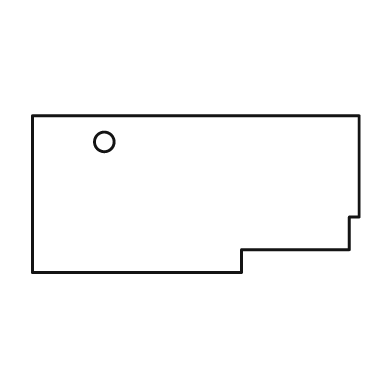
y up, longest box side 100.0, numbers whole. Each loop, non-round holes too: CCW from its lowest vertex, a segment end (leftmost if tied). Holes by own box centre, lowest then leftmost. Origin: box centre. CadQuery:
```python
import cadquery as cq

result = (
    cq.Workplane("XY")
    .moveTo(-50.0, -24.0)
    .lineTo(14.0, -24.0)
    .lineTo(14.0, -17.0)
    .lineTo(47.0, -17.0)
    .lineTo(47.0, -7.0)
    .lineTo(50.0, -7.0)
    .lineTo(50.0, 24.0)
    .lineTo(-50.0, 24.0)
    .close()
    .moveTo(-28.0, 16.0)
    .circle(3.0)
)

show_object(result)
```